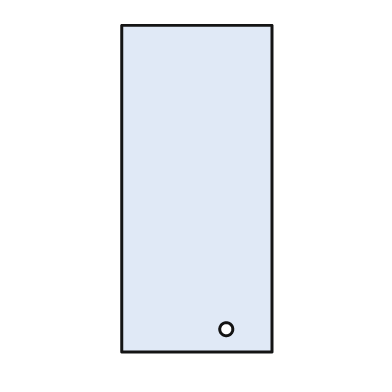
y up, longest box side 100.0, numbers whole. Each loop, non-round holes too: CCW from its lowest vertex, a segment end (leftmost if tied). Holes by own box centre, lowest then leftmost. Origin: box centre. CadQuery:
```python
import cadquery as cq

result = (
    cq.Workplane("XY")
    .moveTo(-23.0, -50.0)
    .lineTo(23.0, -50.0)
    .lineTo(23.0, 50.0)
    .lineTo(-23.0, 50.0)
    .close()
    .moveTo(9.0, -43.0)
    .circle(2.0)
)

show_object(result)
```